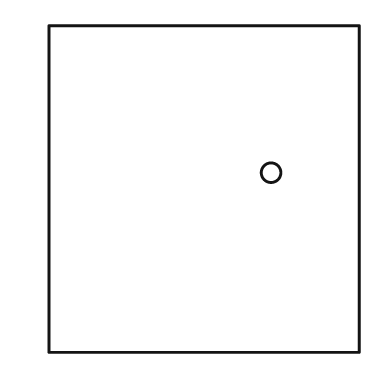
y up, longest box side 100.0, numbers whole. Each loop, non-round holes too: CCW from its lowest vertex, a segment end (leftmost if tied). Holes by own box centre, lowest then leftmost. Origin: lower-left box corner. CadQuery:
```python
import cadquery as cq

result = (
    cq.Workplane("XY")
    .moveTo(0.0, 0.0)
    .lineTo(95.0, 0.0)
    .lineTo(95.0, 100.0)
    .lineTo(0.0, 100.0)
    .close()
    .moveTo(68.0, 55.0)
    .circle(3.0)
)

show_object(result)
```